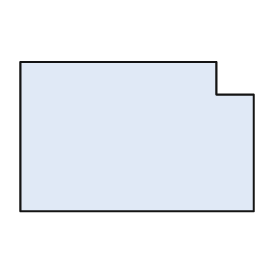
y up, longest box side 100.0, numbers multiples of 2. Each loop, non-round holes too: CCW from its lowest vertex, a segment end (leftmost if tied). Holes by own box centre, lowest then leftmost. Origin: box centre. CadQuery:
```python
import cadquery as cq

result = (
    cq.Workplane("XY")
    .moveTo(-50.0, -32.0)
    .lineTo(50.0, -32.0)
    .lineTo(50.0, 18.0)
    .lineTo(34.0, 18.0)
    .lineTo(34.0, 32.0)
    .lineTo(-50.0, 32.0)
    .close()
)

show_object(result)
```